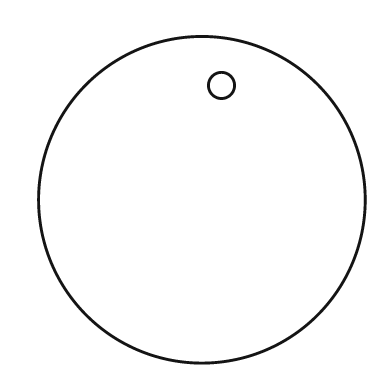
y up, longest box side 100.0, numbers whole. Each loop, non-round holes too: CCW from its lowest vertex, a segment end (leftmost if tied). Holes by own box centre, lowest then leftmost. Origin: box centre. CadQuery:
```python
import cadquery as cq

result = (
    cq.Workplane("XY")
    .moveTo(0.0, 0.0)
    .circle(50.0)
    .moveTo(6.0, 35.0)
    .circle(4.0)
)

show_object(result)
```